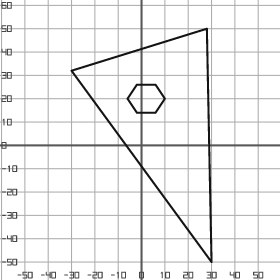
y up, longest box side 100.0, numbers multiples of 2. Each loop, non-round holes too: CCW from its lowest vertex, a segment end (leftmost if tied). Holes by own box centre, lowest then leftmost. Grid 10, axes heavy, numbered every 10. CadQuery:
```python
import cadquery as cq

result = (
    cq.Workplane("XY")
    .moveTo(30.0, -50.0)
    .lineTo(28.0, 50.0)
    .lineTo(-30.0, 32.0)
    .close()
    .moveTo(-2.0, 14.0)
    .lineTo(6.0, 14.0)
    .lineTo(10.0, 20.0)
    .lineTo(6.0, 26.0)
    .lineTo(-2.0, 26.0)
    .lineTo(-6.0, 20.0)
    .close()
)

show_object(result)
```